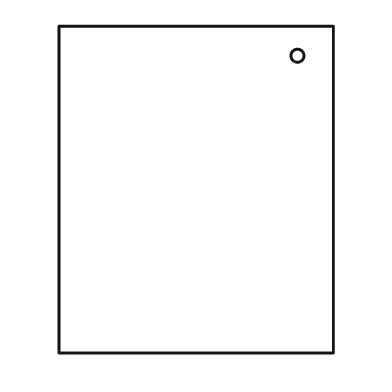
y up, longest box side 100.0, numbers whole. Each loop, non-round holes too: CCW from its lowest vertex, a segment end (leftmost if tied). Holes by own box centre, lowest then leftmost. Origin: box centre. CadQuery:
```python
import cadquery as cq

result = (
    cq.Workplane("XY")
    .moveTo(-42.0, -50.0)
    .lineTo(42.0, -50.0)
    .lineTo(42.0, 50.0)
    .lineTo(-42.0, 50.0)
    .close()
    .moveTo(31.0, 41.0)
    .circle(2.0)
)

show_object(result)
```